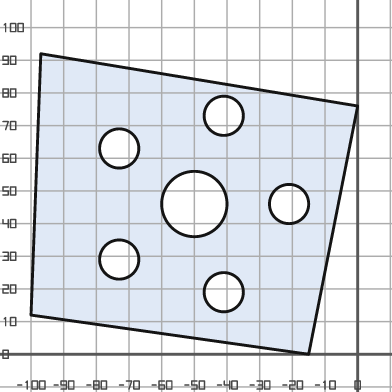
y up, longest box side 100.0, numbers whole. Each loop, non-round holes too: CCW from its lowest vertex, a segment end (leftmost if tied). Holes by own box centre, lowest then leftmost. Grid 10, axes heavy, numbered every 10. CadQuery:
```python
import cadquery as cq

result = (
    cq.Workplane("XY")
    .moveTo(-15.0, 0.0)
    .lineTo(0.0, 76.0)
    .lineTo(-97.0, 92.0)
    .lineTo(-100.0, 12.0)
    .close()
    .moveTo(-41.0, 19.0)
    .circle(6.0)
    .moveTo(-73.0, 29.0)
    .circle(6.0)
    .moveTo(-50.0, 46.0)
    .circle(10.0)
    .moveTo(-21.0, 46.0)
    .circle(6.0)
    .moveTo(-73.0, 63.0)
    .circle(6.0)
    .moveTo(-41.0, 73.0)
    .circle(6.0)
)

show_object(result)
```